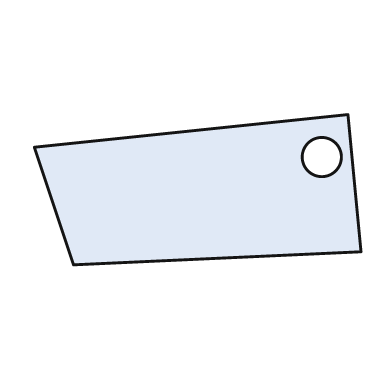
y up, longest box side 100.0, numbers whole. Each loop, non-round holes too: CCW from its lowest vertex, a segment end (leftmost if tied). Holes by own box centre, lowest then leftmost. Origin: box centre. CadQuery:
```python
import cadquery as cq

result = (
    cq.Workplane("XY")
    .moveTo(-38.0, -23.0)
    .lineTo(50.0, -19.0)
    .lineTo(46.0, 23.0)
    .lineTo(-50.0, 13.0)
    .close()
    .moveTo(38.0, 10.0)
    .circle(6.0)
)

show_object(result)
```